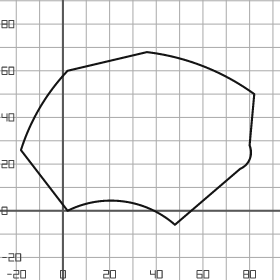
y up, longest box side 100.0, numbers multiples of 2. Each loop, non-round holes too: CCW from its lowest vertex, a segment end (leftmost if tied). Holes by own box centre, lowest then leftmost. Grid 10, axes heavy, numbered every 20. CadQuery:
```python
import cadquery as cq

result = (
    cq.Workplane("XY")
    .moveTo(48.0, -6.0)
    .lineTo(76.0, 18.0)
    .threePointArc((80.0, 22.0), (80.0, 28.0))
    .lineTo(82.0, 50.0)
    .threePointArc((60.0, 62.0), (36.0, 68.0))
    .lineTo(2.0, 60.0)
    .threePointArc((-10.0, 44.0), (-18.0, 26.0))
    .lineTo(2.0, 0.0)
    .threePointArc((26.0, 4.0), (48.0, -6.0))
    .close()
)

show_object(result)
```